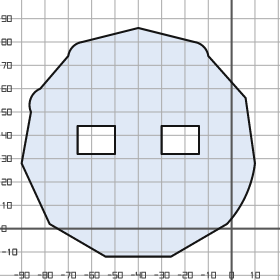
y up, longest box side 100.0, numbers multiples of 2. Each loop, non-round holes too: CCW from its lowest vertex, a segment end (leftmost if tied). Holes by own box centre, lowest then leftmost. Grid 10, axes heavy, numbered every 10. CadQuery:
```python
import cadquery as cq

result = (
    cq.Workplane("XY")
    .moveTo(-54.0, -12.0)
    .lineTo(-26.0, -12.0)
    .lineTo(-2.0, 2.0)
    .threePointArc((6.0, 14.0), (10.0, 28.0))
    .lineTo(6.0, 56.0)
    .lineTo(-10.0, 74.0)
    .threePointArc((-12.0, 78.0), (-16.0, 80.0))
    .lineTo(-40.0, 86.0)
    .lineTo(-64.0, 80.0)
    .threePointArc((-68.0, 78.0), (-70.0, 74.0))
    .lineTo(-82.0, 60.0)
    .threePointArc((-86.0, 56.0), (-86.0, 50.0))
    .lineTo(-90.0, 28.0)
    .lineTo(-78.0, 2.0)
    .close()
    .moveTo(-66.0, 32.0)
    .lineTo(-50.0, 32.0)
    .lineTo(-50.0, 44.0)
    .lineTo(-66.0, 44.0)
    .close()
    .moveTo(-30.0, 32.0)
    .lineTo(-14.0, 32.0)
    .lineTo(-14.0, 44.0)
    .lineTo(-30.0, 44.0)
    .close()
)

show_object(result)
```